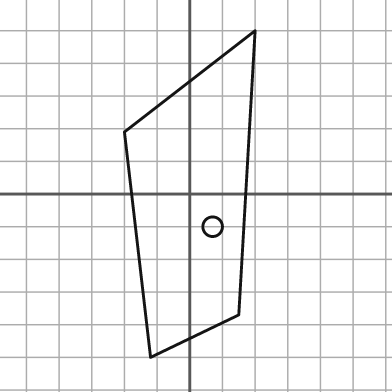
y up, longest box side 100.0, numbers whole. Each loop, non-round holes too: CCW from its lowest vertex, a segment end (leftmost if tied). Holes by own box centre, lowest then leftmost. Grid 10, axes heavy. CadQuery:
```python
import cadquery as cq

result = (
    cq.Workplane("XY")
    .moveTo(-12.0, -50.0)
    .lineTo(15.0, -37.0)
    .lineTo(20.0, 50.0)
    .lineTo(-20.0, 19.0)
    .close()
    .moveTo(7.0, -10.0)
    .circle(3.0)
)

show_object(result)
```